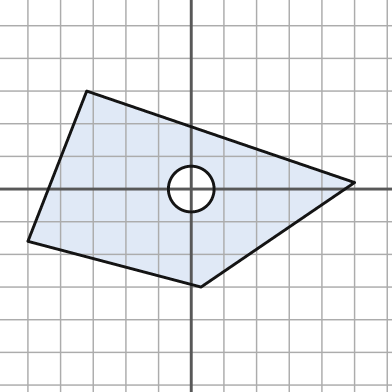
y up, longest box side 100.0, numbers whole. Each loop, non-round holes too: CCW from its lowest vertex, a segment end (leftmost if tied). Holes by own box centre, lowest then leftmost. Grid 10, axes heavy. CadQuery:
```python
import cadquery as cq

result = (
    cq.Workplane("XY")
    .moveTo(3.0, -30.0)
    .lineTo(50.0, 2.0)
    .lineTo(-32.0, 30.0)
    .lineTo(-50.0, -16.0)
    .close()
    .moveTo(0.0, 0.0)
    .circle(7.0)
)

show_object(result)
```